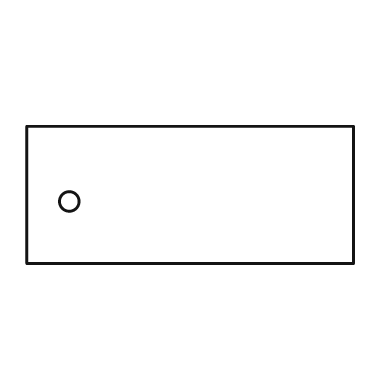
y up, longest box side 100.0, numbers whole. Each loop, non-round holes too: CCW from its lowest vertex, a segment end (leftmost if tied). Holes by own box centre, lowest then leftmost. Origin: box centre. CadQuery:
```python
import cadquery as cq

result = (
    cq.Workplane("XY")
    .moveTo(-50.0, -21.0)
    .lineTo(50.0, -21.0)
    .lineTo(50.0, 21.0)
    .lineTo(-50.0, 21.0)
    .close()
    .moveTo(-37.0, -2.0)
    .circle(3.0)
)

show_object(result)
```